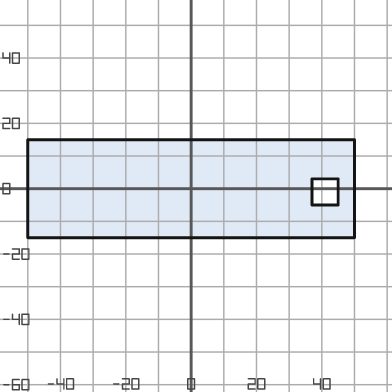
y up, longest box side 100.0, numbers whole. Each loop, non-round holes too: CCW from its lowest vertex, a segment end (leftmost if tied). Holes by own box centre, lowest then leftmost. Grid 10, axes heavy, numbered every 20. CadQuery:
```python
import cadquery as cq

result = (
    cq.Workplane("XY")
    .moveTo(-50.0, -15.0)
    .lineTo(50.0, -15.0)
    .lineTo(50.0, 15.0)
    .lineTo(-50.0, 15.0)
    .close()
    .moveTo(37.0, -5.0)
    .lineTo(45.0, -5.0)
    .lineTo(45.0, 3.0)
    .lineTo(37.0, 3.0)
    .close()
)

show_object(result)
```